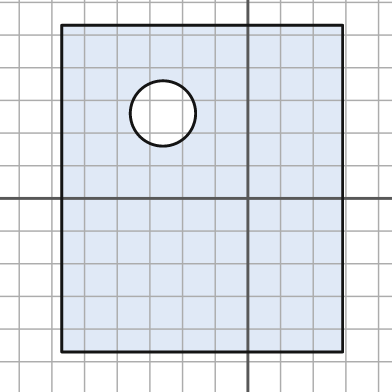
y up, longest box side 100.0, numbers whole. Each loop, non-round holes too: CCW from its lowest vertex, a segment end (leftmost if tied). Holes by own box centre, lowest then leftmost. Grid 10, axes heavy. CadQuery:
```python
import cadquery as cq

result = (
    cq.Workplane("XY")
    .moveTo(-57.0, -47.0)
    .lineTo(29.0, -47.0)
    .lineTo(29.0, 53.0)
    .lineTo(-57.0, 53.0)
    .close()
    .moveTo(-26.0, 26.0)
    .circle(10.0)
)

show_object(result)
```